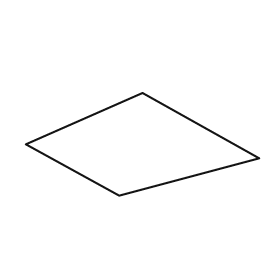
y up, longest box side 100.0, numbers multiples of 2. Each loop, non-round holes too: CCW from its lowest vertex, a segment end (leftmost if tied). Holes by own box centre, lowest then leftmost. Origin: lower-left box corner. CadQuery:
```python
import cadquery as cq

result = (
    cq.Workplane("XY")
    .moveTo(40.0, 0.0)
    .lineTo(100.0, 16.0)
    .lineTo(50.0, 44.0)
    .lineTo(0.0, 22.0)
    .close()
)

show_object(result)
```